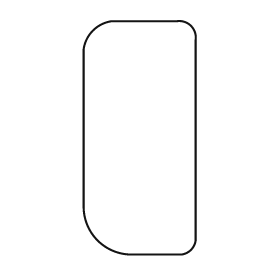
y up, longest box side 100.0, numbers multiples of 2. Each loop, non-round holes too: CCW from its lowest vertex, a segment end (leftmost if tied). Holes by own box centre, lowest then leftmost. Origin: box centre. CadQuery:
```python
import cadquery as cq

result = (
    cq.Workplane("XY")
    .moveTo(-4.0, -50.0)
    .lineTo(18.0, -50.0)
    .threePointArc((22.0, -48.0), (24.0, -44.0))
    .lineTo(24.0, 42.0)
    .threePointArc((22.0, 48.0), (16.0, 50.0))
    .lineTo(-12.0, 50.0)
    .threePointArc((-20.0, 46.0), (-24.0, 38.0))
    .lineTo(-24.0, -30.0)
    .threePointArc((-18.0, -44.0), (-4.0, -50.0))
    .close()
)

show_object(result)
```